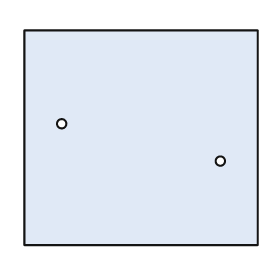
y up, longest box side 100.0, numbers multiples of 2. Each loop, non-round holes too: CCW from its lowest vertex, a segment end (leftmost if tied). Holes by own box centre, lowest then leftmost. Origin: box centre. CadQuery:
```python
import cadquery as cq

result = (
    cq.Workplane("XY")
    .moveTo(-50.0, -46.0)
    .lineTo(50.0, -46.0)
    .lineTo(50.0, 46.0)
    .lineTo(-50.0, 46.0)
    .close()
    .moveTo(34.0, -10.0)
    .circle(2.0)
    .moveTo(-34.0, 6.0)
    .circle(2.0)
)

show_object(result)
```